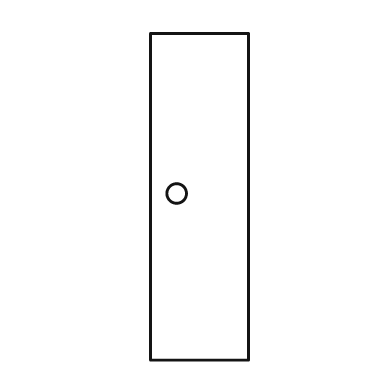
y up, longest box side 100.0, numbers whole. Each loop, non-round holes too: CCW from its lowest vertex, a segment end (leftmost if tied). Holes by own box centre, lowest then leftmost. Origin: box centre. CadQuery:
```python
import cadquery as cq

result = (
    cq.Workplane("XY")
    .moveTo(-15.0, -50.0)
    .lineTo(15.0, -50.0)
    .lineTo(15.0, 50.0)
    .lineTo(-15.0, 50.0)
    .close()
    .moveTo(-7.0, 1.0)
    .circle(3.0)
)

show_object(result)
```